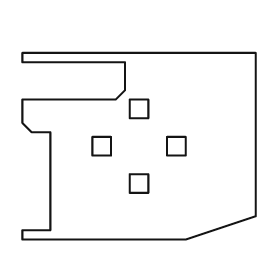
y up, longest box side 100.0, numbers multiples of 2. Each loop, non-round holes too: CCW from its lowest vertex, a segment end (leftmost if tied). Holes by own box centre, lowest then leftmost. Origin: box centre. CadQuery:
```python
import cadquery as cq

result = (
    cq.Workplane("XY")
    .moveTo(-50.0, -40.0)
    .lineTo(20.0, -40.0)
    .lineTo(50.0, -30.0)
    .lineTo(50.0, 40.0)
    .lineTo(-50.0, 40.0)
    .lineTo(-50.0, 36.0)
    .lineTo(-6.0, 36.0)
    .lineTo(-6.0, 24.0)
    .lineTo(-10.0, 20.0)
    .lineTo(-50.0, 20.0)
    .lineTo(-50.0, 10.0)
    .lineTo(-46.0, 6.0)
    .lineTo(-38.0, 6.0)
    .lineTo(-38.0, -36.0)
    .lineTo(-50.0, -36.0)
    .close()
    .moveTo(-4.0, -20.0)
    .lineTo(4.0, -20.0)
    .lineTo(4.0, -12.0)
    .lineTo(-4.0, -12.0)
    .close()
    .moveTo(-20.0, -4.0)
    .lineTo(-12.0, -4.0)
    .lineTo(-12.0, 4.0)
    .lineTo(-20.0, 4.0)
    .close()
    .moveTo(12.0, -4.0)
    .lineTo(20.0, -4.0)
    .lineTo(20.0, 4.0)
    .lineTo(12.0, 4.0)
    .close()
    .moveTo(-4.0, 12.0)
    .lineTo(4.0, 12.0)
    .lineTo(4.0, 20.0)
    .lineTo(-4.0, 20.0)
    .close()
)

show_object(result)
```